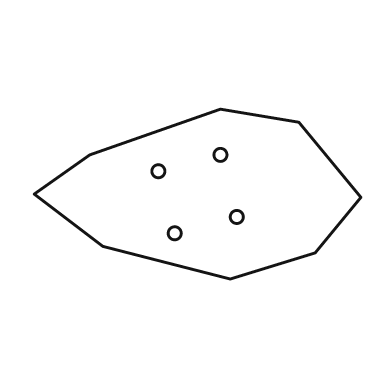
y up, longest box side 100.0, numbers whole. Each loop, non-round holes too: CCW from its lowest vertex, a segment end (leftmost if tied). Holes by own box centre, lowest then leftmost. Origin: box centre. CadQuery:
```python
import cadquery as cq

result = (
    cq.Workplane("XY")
    .moveTo(10.0, -26.0)
    .lineTo(36.0, -18.0)
    .lineTo(50.0, -1.0)
    .lineTo(31.0, 22.0)
    .lineTo(7.0, 26.0)
    .lineTo(-33.0, 12.0)
    .lineTo(-50.0, 0.0)
    .lineTo(-29.0, -16.0)
    .close()
    .moveTo(-7.0, -12.0)
    .circle(2.0)
    .moveTo(12.0, -7.0)
    .circle(2.0)
    .moveTo(-12.0, 7.0)
    .circle(2.0)
    .moveTo(7.0, 12.0)
    .circle(2.0)
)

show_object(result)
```